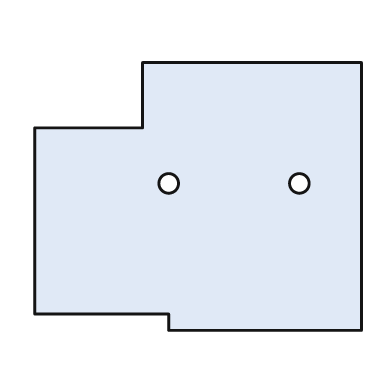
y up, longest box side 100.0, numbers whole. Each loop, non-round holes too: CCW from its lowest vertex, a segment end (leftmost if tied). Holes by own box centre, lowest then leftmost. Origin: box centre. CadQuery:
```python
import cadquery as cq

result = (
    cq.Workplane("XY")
    .moveTo(-9.0, -41.0)
    .lineTo(50.0, -41.0)
    .lineTo(50.0, 41.0)
    .lineTo(-17.0, 41.0)
    .lineTo(-17.0, 21.0)
    .lineTo(-50.0, 21.0)
    .lineTo(-50.0, -36.0)
    .lineTo(-9.0, -36.0)
    .close()
    .moveTo(-9.0, 4.0)
    .circle(3.0)
    .moveTo(31.0, 4.0)
    .circle(3.0)
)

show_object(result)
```